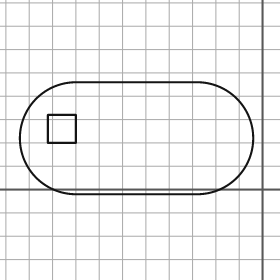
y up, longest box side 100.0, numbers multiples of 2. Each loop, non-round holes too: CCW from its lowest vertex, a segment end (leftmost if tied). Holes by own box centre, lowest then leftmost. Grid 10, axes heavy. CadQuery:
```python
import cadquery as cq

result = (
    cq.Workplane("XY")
    .moveTo(-80.0, -2.0)
    .lineTo(-28.0, -2.0)
    .threePointArc((-4.0, 22.0), (-28.0, 46.0))
    .lineTo(-80.0, 46.0)
    .threePointArc((-104.0, 22.0), (-80.0, -2.0))
    .close()
    .moveTo(-92.0, 20.0)
    .lineTo(-80.0, 20.0)
    .lineTo(-80.0, 32.0)
    .lineTo(-92.0, 32.0)
    .close()
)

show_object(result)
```